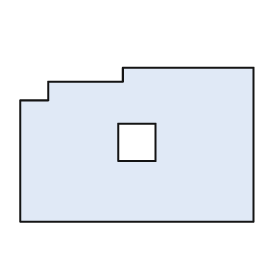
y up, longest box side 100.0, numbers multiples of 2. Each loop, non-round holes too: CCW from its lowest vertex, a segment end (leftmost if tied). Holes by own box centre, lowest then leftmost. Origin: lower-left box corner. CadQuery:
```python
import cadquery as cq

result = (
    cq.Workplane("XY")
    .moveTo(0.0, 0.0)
    .lineTo(100.0, 0.0)
    .lineTo(100.0, 66.0)
    .lineTo(44.0, 66.0)
    .lineTo(44.0, 60.0)
    .lineTo(12.0, 60.0)
    .lineTo(12.0, 52.0)
    .lineTo(0.0, 52.0)
    .close()
    .moveTo(42.0, 26.0)
    .lineTo(58.0, 26.0)
    .lineTo(58.0, 42.0)
    .lineTo(42.0, 42.0)
    .close()
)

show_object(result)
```